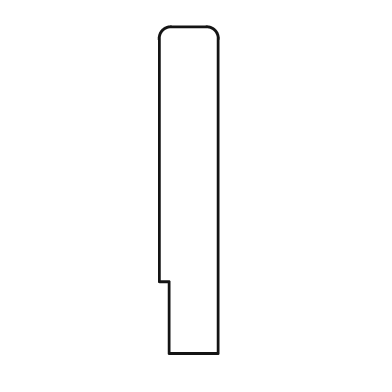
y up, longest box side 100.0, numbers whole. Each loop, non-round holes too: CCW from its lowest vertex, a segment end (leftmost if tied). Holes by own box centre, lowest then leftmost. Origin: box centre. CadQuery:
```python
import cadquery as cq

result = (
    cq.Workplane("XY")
    .moveTo(-6.0, -50.0)
    .lineTo(9.0, -50.0)
    .lineTo(9.0, 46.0)
    .threePointArc((8.0, 49.0), (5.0, 50.0))
    .lineTo(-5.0, 50.0)
    .threePointArc((-8.0, 49.0), (-9.0, 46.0))
    .lineTo(-9.0, -28.0)
    .lineTo(-6.0, -28.0)
    .close()
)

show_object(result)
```